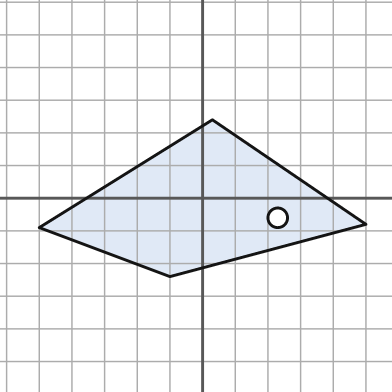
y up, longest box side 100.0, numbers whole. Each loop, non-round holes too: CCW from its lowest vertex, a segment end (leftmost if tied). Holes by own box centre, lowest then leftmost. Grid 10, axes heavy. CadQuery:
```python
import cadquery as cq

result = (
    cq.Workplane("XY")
    .moveTo(-10.0, -24.0)
    .lineTo(50.0, -8.0)
    .lineTo(3.0, 24.0)
    .lineTo(-50.0, -9.0)
    .close()
    .moveTo(23.0, -6.0)
    .circle(3.0)
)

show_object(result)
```